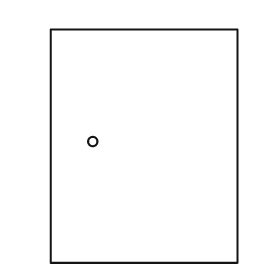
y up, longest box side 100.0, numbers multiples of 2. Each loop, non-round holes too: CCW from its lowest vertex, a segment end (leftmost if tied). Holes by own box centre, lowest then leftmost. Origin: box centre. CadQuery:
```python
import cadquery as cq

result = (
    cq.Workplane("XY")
    .moveTo(-40.0, -50.0)
    .lineTo(40.0, -50.0)
    .lineTo(40.0, 50.0)
    .lineTo(-40.0, 50.0)
    .close()
    .moveTo(-22.0, 2.0)
    .circle(2.0)
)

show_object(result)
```